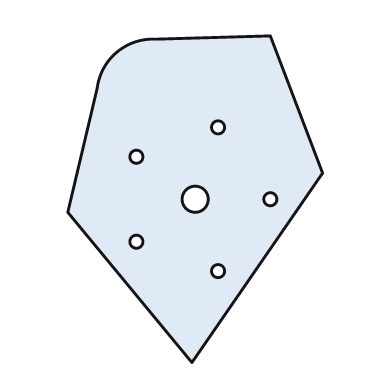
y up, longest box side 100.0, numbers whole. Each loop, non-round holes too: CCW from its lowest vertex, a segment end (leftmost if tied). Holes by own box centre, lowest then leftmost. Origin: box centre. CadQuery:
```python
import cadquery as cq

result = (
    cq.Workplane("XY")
    .moveTo(-1.0, -50.0)
    .lineTo(39.0, 8.0)
    .lineTo(23.0, 50.0)
    .lineTo(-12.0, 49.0)
    .threePointArc((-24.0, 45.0), (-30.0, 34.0))
    .lineTo(-39.0, -4.0)
    .close()
    .moveTo(7.0, -22.0)
    .circle(2.0)
    .moveTo(-18.0, -13.0)
    .circle(2.0)
    .moveTo(0.0, 0.0)
    .circle(4.0)
    .moveTo(23.0, 0.0)
    .circle(2.0)
    .moveTo(-18.0, 13.0)
    .circle(2.0)
    .moveTo(7.0, 22.0)
    .circle(2.0)
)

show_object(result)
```